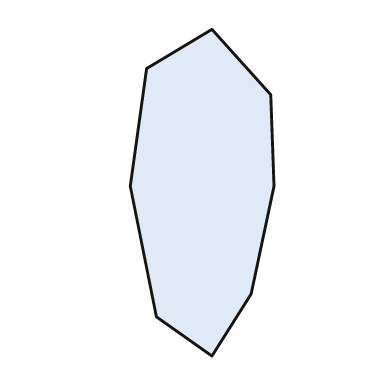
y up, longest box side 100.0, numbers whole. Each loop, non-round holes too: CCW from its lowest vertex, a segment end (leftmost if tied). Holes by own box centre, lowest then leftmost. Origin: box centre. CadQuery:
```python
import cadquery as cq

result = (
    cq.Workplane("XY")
    .moveTo(3.0, -50.0)
    .lineTo(15.0, -31.0)
    .lineTo(22.0, 2.0)
    .lineTo(21.0, 30.0)
    .lineTo(3.0, 50.0)
    .lineTo(-17.0, 38.0)
    .lineTo(-22.0, 2.0)
    .lineTo(-14.0, -38.0)
    .close()
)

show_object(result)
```